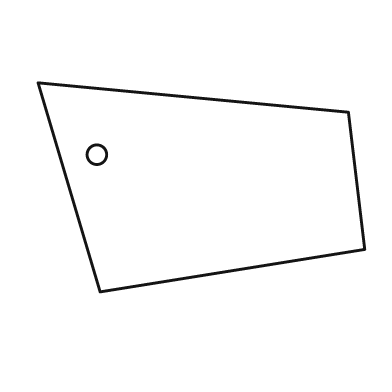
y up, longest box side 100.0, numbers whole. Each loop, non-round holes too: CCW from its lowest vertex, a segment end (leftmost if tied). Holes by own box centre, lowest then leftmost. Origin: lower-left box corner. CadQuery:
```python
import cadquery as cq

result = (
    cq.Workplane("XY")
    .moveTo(19.0, 0.0)
    .lineTo(100.0, 13.0)
    .lineTo(95.0, 55.0)
    .lineTo(0.0, 64.0)
    .close()
    .moveTo(18.0, 42.0)
    .circle(3.0)
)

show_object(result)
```